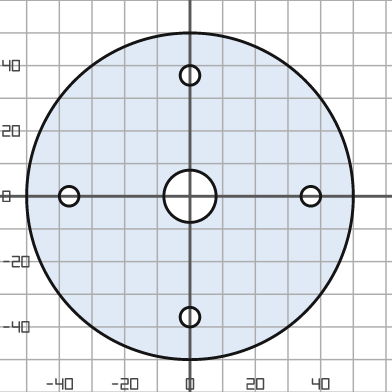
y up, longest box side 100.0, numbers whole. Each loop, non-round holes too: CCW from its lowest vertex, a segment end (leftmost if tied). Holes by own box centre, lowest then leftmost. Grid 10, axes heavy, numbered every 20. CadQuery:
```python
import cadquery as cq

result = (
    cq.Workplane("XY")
    .moveTo(0.0, 0.0)
    .circle(50.0)
    .moveTo(0.0, -37.0)
    .circle(3.0)
    .moveTo(-37.0, 0.0)
    .circle(3.0)
    .moveTo(0.0, 0.0)
    .circle(8.0)
    .moveTo(37.0, 0.0)
    .circle(3.0)
    .moveTo(0.0, 37.0)
    .circle(3.0)
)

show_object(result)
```